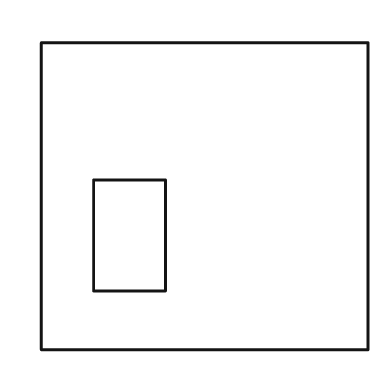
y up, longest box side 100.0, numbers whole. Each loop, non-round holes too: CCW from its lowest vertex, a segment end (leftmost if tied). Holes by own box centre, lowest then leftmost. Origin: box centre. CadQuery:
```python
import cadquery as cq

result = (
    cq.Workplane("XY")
    .moveTo(-50.0, -47.0)
    .lineTo(50.0, -47.0)
    .lineTo(50.0, 47.0)
    .lineTo(-50.0, 47.0)
    .close()
    .moveTo(-34.0, -29.0)
    .lineTo(-12.0, -29.0)
    .lineTo(-12.0, 5.0)
    .lineTo(-34.0, 5.0)
    .close()
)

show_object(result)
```